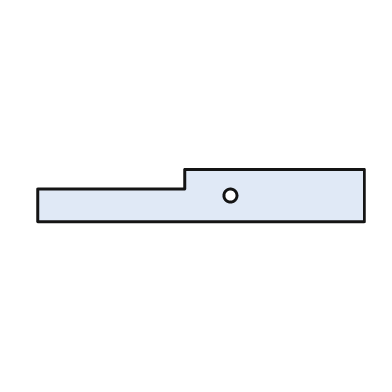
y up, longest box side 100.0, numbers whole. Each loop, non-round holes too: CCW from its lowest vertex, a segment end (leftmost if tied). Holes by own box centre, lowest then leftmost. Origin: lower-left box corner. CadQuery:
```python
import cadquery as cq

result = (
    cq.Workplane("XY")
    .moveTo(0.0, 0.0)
    .lineTo(100.0, 0.0)
    .lineTo(100.0, 16.0)
    .lineTo(45.0, 16.0)
    .lineTo(45.0, 10.0)
    .lineTo(0.0, 10.0)
    .close()
    .moveTo(59.0, 8.0)
    .circle(2.0)
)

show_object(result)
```